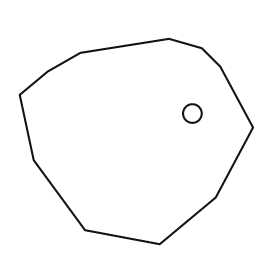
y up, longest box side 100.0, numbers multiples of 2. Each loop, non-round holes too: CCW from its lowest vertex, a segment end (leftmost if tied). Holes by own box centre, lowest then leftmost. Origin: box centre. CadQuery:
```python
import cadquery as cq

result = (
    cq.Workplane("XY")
    .moveTo(10.0, -44.0)
    .lineTo(34.0, -24.0)
    .lineTo(50.0, 6.0)
    .lineTo(36.0, 32.0)
    .lineTo(28.0, 40.0)
    .lineTo(14.0, 44.0)
    .lineTo(-24.0, 38.0)
    .lineTo(-38.0, 30.0)
    .lineTo(-50.0, 20.0)
    .lineTo(-44.0, -8.0)
    .lineTo(-22.0, -38.0)
    .close()
    .moveTo(24.0, 12.0)
    .circle(4.0)
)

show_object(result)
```